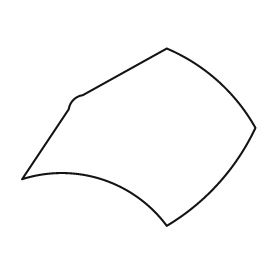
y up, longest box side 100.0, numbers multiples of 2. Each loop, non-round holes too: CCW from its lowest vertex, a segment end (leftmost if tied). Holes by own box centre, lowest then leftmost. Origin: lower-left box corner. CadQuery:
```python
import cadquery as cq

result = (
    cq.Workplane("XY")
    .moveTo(62.0, 0.0)
    .threePointArc((84.0, 18.0), (100.0, 42.0))
    .threePointArc((84.0, 62.0), (62.0, 76.0))
    .lineTo(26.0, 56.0)
    .threePointArc((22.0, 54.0), (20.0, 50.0))
    .lineTo(0.0, 20.0)
    .threePointArc((34.0, 20.0), (62.0, 0.0))
    .close()
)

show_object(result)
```